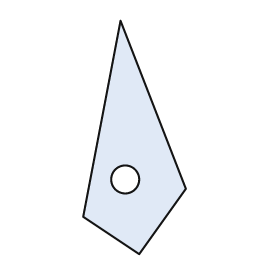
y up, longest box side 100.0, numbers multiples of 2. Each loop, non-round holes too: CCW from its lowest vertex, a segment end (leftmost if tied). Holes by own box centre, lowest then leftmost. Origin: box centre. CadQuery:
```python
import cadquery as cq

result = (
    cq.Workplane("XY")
    .moveTo(2.0, -50.0)
    .lineTo(22.0, -22.0)
    .lineTo(-6.0, 50.0)
    .lineTo(-22.0, -34.0)
    .close()
    .moveTo(-4.0, -18.0)
    .circle(6.0)
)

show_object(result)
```